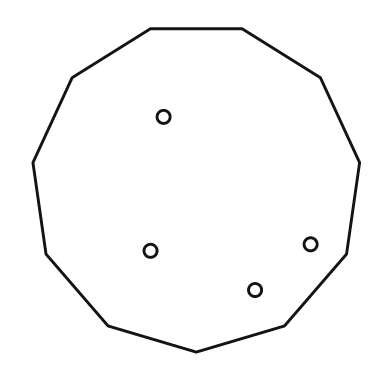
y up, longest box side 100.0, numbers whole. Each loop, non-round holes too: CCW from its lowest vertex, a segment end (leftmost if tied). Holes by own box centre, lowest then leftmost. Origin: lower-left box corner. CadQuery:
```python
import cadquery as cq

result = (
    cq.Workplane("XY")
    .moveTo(50.0, 0.0)
    .lineTo(77.0, 8.0)
    .lineTo(96.0, 30.0)
    .lineTo(100.0, 58.0)
    .lineTo(88.0, 84.0)
    .lineTo(64.0, 99.0)
    .lineTo(36.0, 99.0)
    .lineTo(12.0, 84.0)
    .lineTo(0.0, 58.0)
    .lineTo(4.0, 30.0)
    .lineTo(23.0, 8.0)
    .close()
    .moveTo(68.0, 19.0)
    .circle(2.0)
    .moveTo(36.0, 31.0)
    .circle(2.0)
    .moveTo(85.0, 33.0)
    .circle(2.0)
    .moveTo(40.0, 72.0)
    .circle(2.0)
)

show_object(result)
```